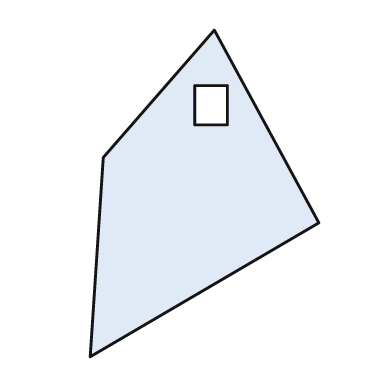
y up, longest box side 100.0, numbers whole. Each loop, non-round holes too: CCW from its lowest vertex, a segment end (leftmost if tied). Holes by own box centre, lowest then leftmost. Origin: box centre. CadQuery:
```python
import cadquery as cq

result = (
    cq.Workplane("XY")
    .moveTo(-35.0, -50.0)
    .lineTo(35.0, -9.0)
    .lineTo(3.0, 50.0)
    .lineTo(-31.0, 11.0)
    .close()
    .moveTo(-3.0, 21.0)
    .lineTo(7.0, 21.0)
    .lineTo(7.0, 33.0)
    .lineTo(-3.0, 33.0)
    .close()
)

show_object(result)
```